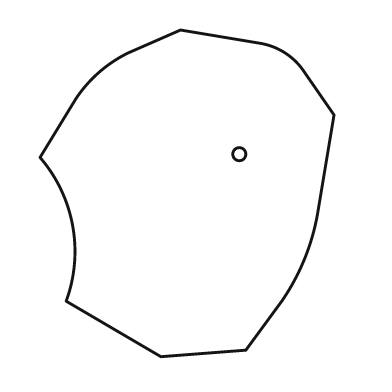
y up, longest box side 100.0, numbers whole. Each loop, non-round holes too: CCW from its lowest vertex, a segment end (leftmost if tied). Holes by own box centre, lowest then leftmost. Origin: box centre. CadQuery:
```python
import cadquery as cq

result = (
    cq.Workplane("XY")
    .moveTo(-8.0, -50.0)
    .lineTo(18.0, -48.0)
    .lineTo(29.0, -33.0)
    .threePointArc((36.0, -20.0), (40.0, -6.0))
    .lineTo(45.0, 24.0)
    .lineTo(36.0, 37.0)
    .threePointArc((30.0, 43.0), (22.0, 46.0))
    .lineTo(-2.0, 50.0)
    .lineTo(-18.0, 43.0)
    .threePointArc((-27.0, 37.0), (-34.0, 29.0))
    .lineTo(-45.0, 11.0)
    .threePointArc((-35.0, -10.0), (-37.0, -33.0))
    .close()
    .moveTo(16.0, 12.0)
    .circle(2.0)
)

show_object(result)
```